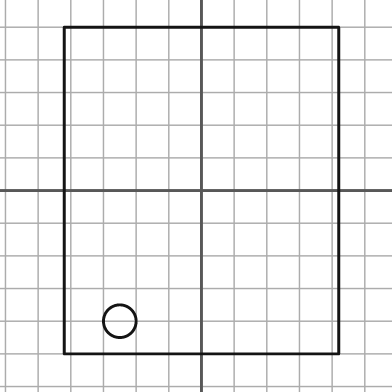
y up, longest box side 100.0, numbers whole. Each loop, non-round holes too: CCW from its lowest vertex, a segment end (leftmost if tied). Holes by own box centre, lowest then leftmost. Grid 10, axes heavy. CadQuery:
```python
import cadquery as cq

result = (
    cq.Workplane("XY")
    .moveTo(-42.0, -50.0)
    .lineTo(42.0, -50.0)
    .lineTo(42.0, 50.0)
    .lineTo(-42.0, 50.0)
    .close()
    .moveTo(-25.0, -40.0)
    .circle(5.0)
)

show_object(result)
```